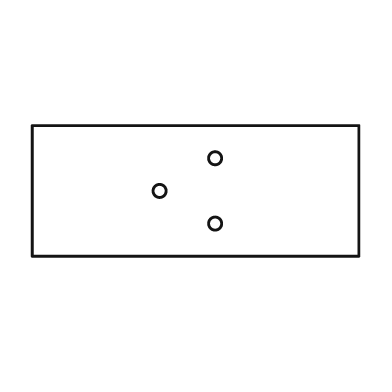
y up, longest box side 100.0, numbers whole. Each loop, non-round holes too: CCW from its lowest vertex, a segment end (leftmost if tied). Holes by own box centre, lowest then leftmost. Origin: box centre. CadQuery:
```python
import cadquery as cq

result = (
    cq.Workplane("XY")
    .moveTo(-50.0, -20.0)
    .lineTo(50.0, -20.0)
    .lineTo(50.0, 20.0)
    .lineTo(-50.0, 20.0)
    .close()
    .moveTo(6.0, -10.0)
    .circle(2.0)
    .moveTo(-11.0, 0.0)
    .circle(2.0)
    .moveTo(6.0, 10.0)
    .circle(2.0)
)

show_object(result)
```